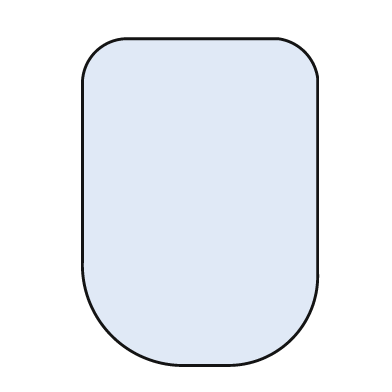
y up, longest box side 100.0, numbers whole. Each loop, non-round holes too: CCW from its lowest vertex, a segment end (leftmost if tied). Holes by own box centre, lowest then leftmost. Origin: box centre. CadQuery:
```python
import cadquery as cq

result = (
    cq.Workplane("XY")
    .moveTo(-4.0, -50.0)
    .lineTo(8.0, -50.0)
    .threePointArc((28.0, -42.0), (36.0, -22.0))
    .lineTo(36.0, 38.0)
    .threePointArc((32.0, 46.0), (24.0, 50.0))
    .lineTo(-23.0, 50.0)
    .threePointArc((-32.0, 46.0), (-36.0, 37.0))
    .lineTo(-36.0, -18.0)
    .threePointArc((-27.0, -41.0), (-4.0, -50.0))
    .close()
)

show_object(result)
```